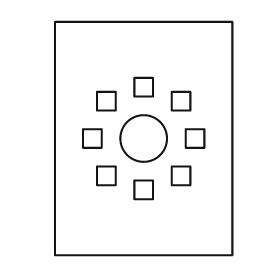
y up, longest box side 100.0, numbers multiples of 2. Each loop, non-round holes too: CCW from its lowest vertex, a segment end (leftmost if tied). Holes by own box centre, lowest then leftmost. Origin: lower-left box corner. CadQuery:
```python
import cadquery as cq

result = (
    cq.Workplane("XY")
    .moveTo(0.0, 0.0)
    .lineTo(76.0, 0.0)
    .lineTo(76.0, 100.0)
    .lineTo(0.0, 100.0)
    .close()
    .moveTo(34.0, 24.0)
    .lineTo(42.0, 24.0)
    .lineTo(42.0, 32.0)
    .lineTo(34.0, 32.0)
    .close()
    .moveTo(18.0, 30.0)
    .lineTo(26.0, 30.0)
    .lineTo(26.0, 38.0)
    .lineTo(18.0, 38.0)
    .close()
    .moveTo(50.0, 30.0)
    .lineTo(58.0, 30.0)
    .lineTo(58.0, 38.0)
    .lineTo(50.0, 38.0)
    .close()
    .moveTo(12.0, 46.0)
    .lineTo(20.0, 46.0)
    .lineTo(20.0, 54.0)
    .lineTo(12.0, 54.0)
    .close()
    .moveTo(38.0, 50.0)
    .circle(10.0)
    .moveTo(56.0, 46.0)
    .lineTo(64.0, 46.0)
    .lineTo(64.0, 54.0)
    .lineTo(56.0, 54.0)
    .close()
    .moveTo(18.0, 62.0)
    .lineTo(26.0, 62.0)
    .lineTo(26.0, 70.0)
    .lineTo(18.0, 70.0)
    .close()
    .moveTo(50.0, 62.0)
    .lineTo(58.0, 62.0)
    .lineTo(58.0, 70.0)
    .lineTo(50.0, 70.0)
    .close()
    .moveTo(34.0, 68.0)
    .lineTo(42.0, 68.0)
    .lineTo(42.0, 76.0)
    .lineTo(34.0, 76.0)
    .close()
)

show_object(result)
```